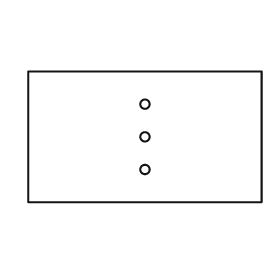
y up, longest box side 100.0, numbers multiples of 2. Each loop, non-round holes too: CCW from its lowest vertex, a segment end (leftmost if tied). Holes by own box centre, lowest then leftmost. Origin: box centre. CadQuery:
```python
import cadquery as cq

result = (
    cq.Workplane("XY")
    .moveTo(-50.0, -28.0)
    .lineTo(50.0, -28.0)
    .lineTo(50.0, 28.0)
    .lineTo(-50.0, 28.0)
    .close()
    .moveTo(0.0, -14.0)
    .circle(2.0)
    .moveTo(0.0, 0.0)
    .circle(2.0)
    .moveTo(0.0, 14.0)
    .circle(2.0)
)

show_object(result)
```